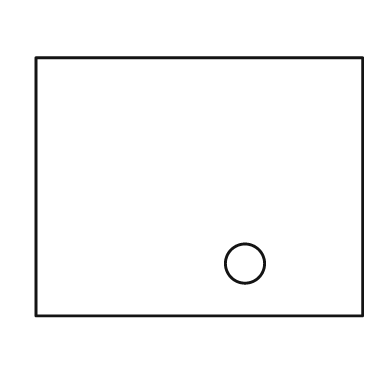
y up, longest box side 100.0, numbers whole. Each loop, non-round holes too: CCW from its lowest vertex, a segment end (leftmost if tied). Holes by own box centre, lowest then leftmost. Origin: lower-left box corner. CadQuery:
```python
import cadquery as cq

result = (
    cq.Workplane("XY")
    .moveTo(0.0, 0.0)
    .lineTo(100.0, 0.0)
    .lineTo(100.0, 79.0)
    .lineTo(0.0, 79.0)
    .close()
    .moveTo(64.0, 16.0)
    .circle(6.0)
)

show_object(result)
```